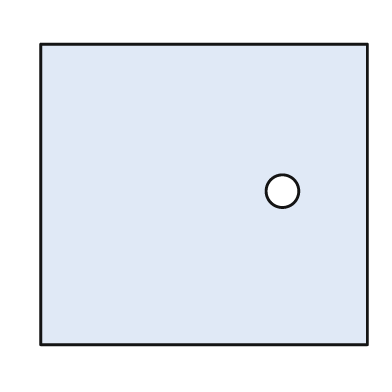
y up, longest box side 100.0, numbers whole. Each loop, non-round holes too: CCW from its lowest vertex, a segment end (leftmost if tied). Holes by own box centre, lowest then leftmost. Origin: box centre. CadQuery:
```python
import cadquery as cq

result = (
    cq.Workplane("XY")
    .moveTo(-50.0, -46.0)
    .lineTo(50.0, -46.0)
    .lineTo(50.0, 46.0)
    .lineTo(-50.0, 46.0)
    .close()
    .moveTo(24.0, 1.0)
    .circle(5.0)
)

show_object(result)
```